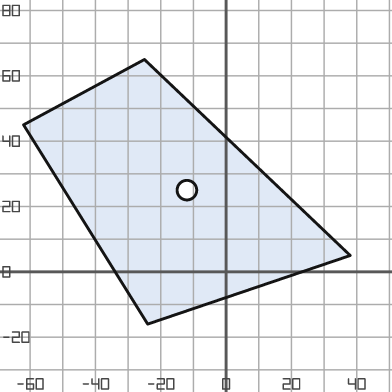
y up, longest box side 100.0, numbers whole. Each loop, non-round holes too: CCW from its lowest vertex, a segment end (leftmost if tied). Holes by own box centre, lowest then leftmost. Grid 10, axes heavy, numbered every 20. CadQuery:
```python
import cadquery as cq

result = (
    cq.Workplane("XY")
    .moveTo(-24.0, -16.0)
    .lineTo(38.0, 5.0)
    .lineTo(-25.0, 65.0)
    .lineTo(-62.0, 45.0)
    .close()
    .moveTo(-12.0, 25.0)
    .circle(3.0)
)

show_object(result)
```